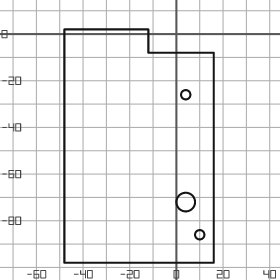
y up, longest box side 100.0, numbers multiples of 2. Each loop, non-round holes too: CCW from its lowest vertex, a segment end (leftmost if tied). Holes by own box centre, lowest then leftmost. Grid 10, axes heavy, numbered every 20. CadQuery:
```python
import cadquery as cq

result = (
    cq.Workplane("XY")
    .moveTo(-48.0, -98.0)
    .lineTo(16.0, -98.0)
    .lineTo(16.0, -8.0)
    .lineTo(-12.0, -8.0)
    .lineTo(-12.0, 2.0)
    .lineTo(-48.0, 2.0)
    .close()
    .moveTo(10.0, -86.0)
    .circle(2.0)
    .moveTo(4.0, -72.0)
    .circle(4.0)
    .moveTo(4.0, -26.0)
    .circle(2.0)
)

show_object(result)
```